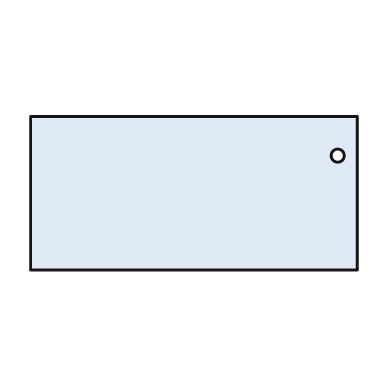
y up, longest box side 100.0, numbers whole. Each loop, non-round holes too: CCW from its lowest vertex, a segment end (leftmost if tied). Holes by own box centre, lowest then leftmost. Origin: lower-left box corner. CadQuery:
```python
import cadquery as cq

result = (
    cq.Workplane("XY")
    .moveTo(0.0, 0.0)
    .lineTo(100.0, 0.0)
    .lineTo(100.0, 47.0)
    .lineTo(0.0, 47.0)
    .close()
    .moveTo(94.0, 35.0)
    .circle(2.0)
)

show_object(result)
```